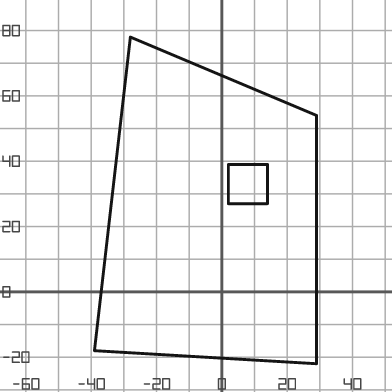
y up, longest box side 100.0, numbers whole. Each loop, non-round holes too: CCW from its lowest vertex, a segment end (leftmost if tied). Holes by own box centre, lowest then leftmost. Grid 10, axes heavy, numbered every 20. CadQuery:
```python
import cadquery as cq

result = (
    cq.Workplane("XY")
    .moveTo(29.0, -22.0)
    .lineTo(29.0, 54.0)
    .lineTo(-28.0, 78.0)
    .lineTo(-39.0, -18.0)
    .close()
    .moveTo(2.0, 27.0)
    .lineTo(14.0, 27.0)
    .lineTo(14.0, 39.0)
    .lineTo(2.0, 39.0)
    .close()
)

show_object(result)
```